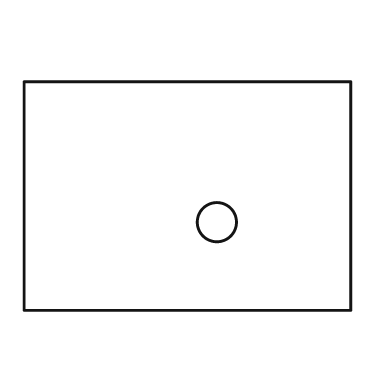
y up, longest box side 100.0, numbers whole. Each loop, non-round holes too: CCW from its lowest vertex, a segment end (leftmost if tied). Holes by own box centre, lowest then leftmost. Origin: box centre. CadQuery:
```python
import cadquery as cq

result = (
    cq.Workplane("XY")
    .moveTo(-50.0, -35.0)
    .lineTo(50.0, -35.0)
    .lineTo(50.0, 35.0)
    .lineTo(-50.0, 35.0)
    .close()
    .moveTo(9.0, -8.0)
    .circle(6.0)
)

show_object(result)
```